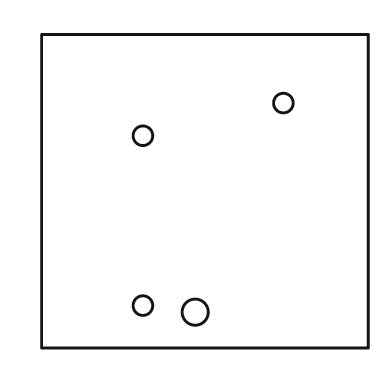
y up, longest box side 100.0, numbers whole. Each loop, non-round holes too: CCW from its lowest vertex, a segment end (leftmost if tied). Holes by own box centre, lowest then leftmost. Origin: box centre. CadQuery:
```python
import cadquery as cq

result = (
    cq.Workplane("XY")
    .moveTo(-50.0, -48.0)
    .lineTo(50.0, -48.0)
    .lineTo(50.0, 48.0)
    .lineTo(-50.0, 48.0)
    .close()
    .moveTo(-3.0, -37.0)
    .circle(4.0)
    .moveTo(-19.0, -35.0)
    .circle(3.0)
    .moveTo(-19.0, 17.0)
    .circle(3.0)
    .moveTo(24.0, 27.0)
    .circle(3.0)
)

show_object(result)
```